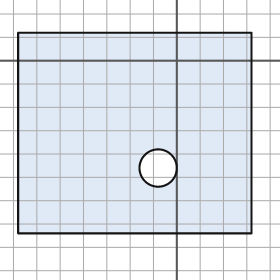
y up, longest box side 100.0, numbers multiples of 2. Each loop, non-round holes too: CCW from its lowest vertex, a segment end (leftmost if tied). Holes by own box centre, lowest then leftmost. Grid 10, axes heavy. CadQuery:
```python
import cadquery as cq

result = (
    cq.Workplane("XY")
    .moveTo(-68.0, -74.0)
    .lineTo(32.0, -74.0)
    .lineTo(32.0, 12.0)
    .lineTo(-68.0, 12.0)
    .close()
    .moveTo(-8.0, -46.0)
    .circle(8.0)
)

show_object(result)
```